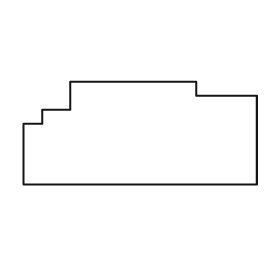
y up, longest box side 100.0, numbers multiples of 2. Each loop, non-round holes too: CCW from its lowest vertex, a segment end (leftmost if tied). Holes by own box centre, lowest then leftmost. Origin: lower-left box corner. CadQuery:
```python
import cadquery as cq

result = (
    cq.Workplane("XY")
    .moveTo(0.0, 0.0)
    .lineTo(100.0, 0.0)
    .lineTo(100.0, 38.0)
    .lineTo(74.0, 38.0)
    .lineTo(74.0, 44.0)
    .lineTo(20.0, 44.0)
    .lineTo(20.0, 32.0)
    .lineTo(8.0, 32.0)
    .lineTo(8.0, 26.0)
    .lineTo(0.0, 26.0)
    .close()
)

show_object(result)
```